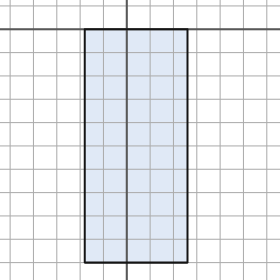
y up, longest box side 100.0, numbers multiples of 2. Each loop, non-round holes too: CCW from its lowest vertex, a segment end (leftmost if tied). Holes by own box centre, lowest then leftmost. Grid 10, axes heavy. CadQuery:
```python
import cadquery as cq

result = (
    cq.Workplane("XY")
    .moveTo(-18.0, -100.0)
    .lineTo(26.0, -100.0)
    .lineTo(26.0, 0.0)
    .lineTo(-18.0, 0.0)
    .close()
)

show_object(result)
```